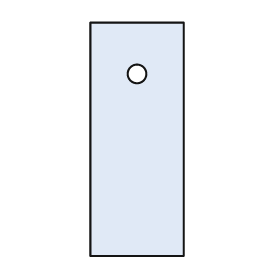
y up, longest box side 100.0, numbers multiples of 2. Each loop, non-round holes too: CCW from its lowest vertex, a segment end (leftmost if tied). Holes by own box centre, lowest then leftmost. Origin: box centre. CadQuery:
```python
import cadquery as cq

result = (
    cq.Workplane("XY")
    .moveTo(-20.0, -50.0)
    .lineTo(20.0, -50.0)
    .lineTo(20.0, 50.0)
    .lineTo(-20.0, 50.0)
    .close()
    .moveTo(0.0, 28.0)
    .circle(4.0)
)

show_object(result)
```